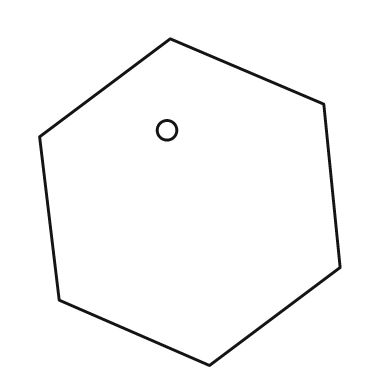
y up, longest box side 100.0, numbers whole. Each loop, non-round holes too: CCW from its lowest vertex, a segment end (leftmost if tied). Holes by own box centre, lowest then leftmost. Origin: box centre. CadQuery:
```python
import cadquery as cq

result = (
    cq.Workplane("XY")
    .moveTo(6.0, -50.0)
    .lineTo(46.0, -20.0)
    .lineTo(41.0, 30.0)
    .lineTo(-6.0, 50.0)
    .lineTo(-46.0, 20.0)
    .lineTo(-40.0, -30.0)
    .close()
    .moveTo(-7.0, 22.0)
    .circle(3.0)
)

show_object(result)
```